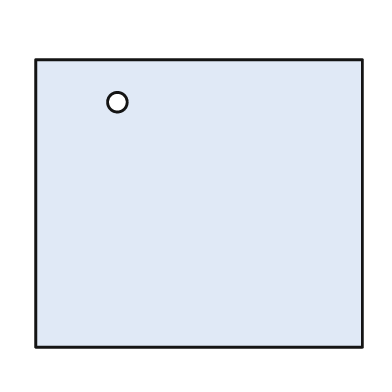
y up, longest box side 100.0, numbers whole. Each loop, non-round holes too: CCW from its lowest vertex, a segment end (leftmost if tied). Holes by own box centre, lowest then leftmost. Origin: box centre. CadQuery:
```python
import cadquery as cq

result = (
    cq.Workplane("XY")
    .moveTo(-50.0, -44.0)
    .lineTo(50.0, -44.0)
    .lineTo(50.0, 44.0)
    .lineTo(-50.0, 44.0)
    .close()
    .moveTo(-25.0, 31.0)
    .circle(3.0)
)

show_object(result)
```